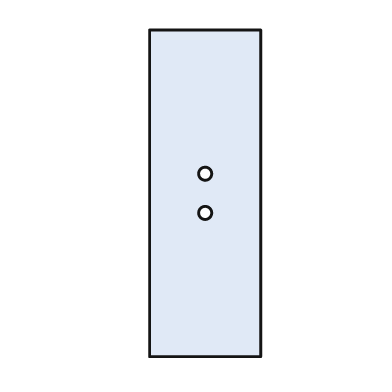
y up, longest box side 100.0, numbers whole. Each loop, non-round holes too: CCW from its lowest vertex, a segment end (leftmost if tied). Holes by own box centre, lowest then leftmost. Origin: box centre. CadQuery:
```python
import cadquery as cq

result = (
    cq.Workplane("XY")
    .moveTo(-17.0, -50.0)
    .lineTo(17.0, -50.0)
    .lineTo(17.0, 50.0)
    .lineTo(-17.0, 50.0)
    .close()
    .moveTo(0.0, -6.0)
    .circle(2.0)
    .moveTo(0.0, 6.0)
    .circle(2.0)
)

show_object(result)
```